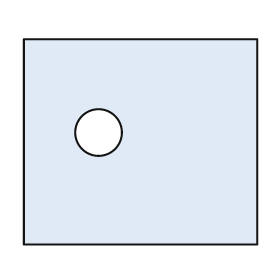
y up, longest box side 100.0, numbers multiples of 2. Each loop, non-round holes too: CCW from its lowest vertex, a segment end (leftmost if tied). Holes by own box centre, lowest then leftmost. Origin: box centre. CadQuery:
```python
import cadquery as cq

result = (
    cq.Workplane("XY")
    .moveTo(-50.0, -44.0)
    .lineTo(50.0, -44.0)
    .lineTo(50.0, 44.0)
    .lineTo(-50.0, 44.0)
    .close()
    .moveTo(-18.0, 4.0)
    .circle(10.0)
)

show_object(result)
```